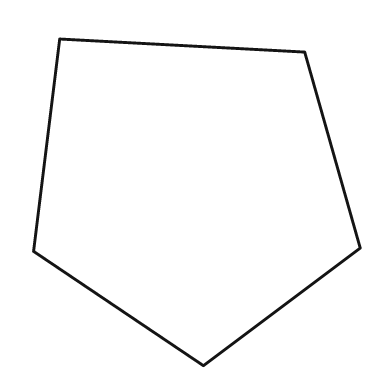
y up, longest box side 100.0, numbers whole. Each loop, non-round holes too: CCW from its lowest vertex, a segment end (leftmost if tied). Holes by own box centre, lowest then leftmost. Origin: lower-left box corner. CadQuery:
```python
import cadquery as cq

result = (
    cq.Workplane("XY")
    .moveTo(52.0, 0.0)
    .lineTo(100.0, 36.0)
    .lineTo(83.0, 96.0)
    .lineTo(8.0, 100.0)
    .lineTo(0.0, 35.0)
    .close()
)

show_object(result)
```